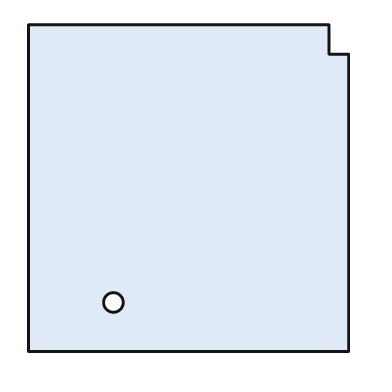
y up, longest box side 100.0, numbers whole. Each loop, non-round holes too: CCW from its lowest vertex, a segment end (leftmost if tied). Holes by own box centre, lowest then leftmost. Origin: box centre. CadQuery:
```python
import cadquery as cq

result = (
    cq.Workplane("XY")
    .moveTo(-49.0, -50.0)
    .lineTo(49.0, -50.0)
    .lineTo(49.0, 41.0)
    .lineTo(43.0, 41.0)
    .lineTo(43.0, 50.0)
    .lineTo(-49.0, 50.0)
    .close()
    .moveTo(-23.0, -35.0)
    .circle(3.0)
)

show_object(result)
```